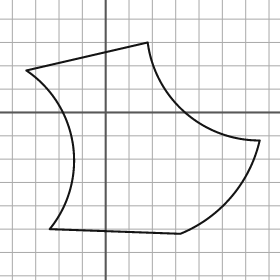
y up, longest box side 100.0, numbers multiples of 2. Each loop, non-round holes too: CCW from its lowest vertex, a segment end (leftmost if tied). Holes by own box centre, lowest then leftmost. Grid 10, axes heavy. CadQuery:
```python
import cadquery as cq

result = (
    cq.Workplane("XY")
    .moveTo(32.0, -52.0)
    .threePointArc((54.0, -36.0), (66.0, -12.0))
    .threePointArc((34.0, 0.0), (18.0, 30.0))
    .lineTo(-34.0, 18.0)
    .threePointArc((-14.0, -14.0), (-24.0, -50.0))
    .close()
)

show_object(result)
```